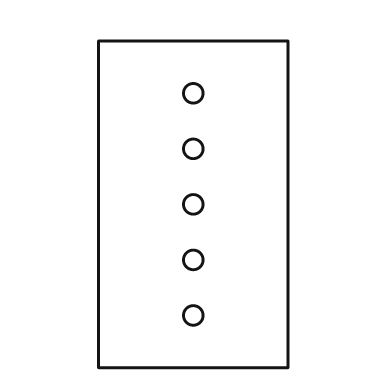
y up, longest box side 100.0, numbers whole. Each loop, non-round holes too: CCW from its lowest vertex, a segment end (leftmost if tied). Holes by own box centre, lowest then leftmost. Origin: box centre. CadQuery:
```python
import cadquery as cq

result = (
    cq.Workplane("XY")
    .moveTo(-29.0, -50.0)
    .lineTo(29.0, -50.0)
    .lineTo(29.0, 50.0)
    .lineTo(-29.0, 50.0)
    .close()
    .moveTo(0.0, -34.0)
    .circle(3.0)
    .moveTo(0.0, -17.0)
    .circle(3.0)
    .moveTo(0.0, 0.0)
    .circle(3.0)
    .moveTo(0.0, 17.0)
    .circle(3.0)
    .moveTo(0.0, 34.0)
    .circle(3.0)
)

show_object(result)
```